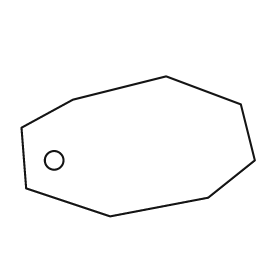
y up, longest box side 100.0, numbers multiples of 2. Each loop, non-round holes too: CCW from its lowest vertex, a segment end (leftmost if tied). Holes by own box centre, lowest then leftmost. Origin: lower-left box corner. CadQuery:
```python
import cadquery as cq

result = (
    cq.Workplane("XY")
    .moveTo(38.0, 0.0)
    .lineTo(80.0, 8.0)
    .lineTo(100.0, 24.0)
    .lineTo(94.0, 48.0)
    .lineTo(62.0, 60.0)
    .lineTo(22.0, 50.0)
    .lineTo(0.0, 38.0)
    .lineTo(2.0, 12.0)
    .close()
    .moveTo(14.0, 24.0)
    .circle(4.0)
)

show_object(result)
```